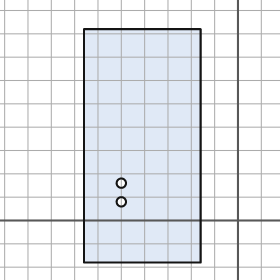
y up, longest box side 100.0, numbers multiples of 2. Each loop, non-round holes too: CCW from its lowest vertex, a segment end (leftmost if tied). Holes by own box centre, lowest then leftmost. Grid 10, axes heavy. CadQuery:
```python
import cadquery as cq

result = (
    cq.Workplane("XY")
    .moveTo(-66.0, -18.0)
    .lineTo(-16.0, -18.0)
    .lineTo(-16.0, 82.0)
    .lineTo(-66.0, 82.0)
    .close()
    .moveTo(-50.0, 8.0)
    .circle(2.0)
    .moveTo(-50.0, 16.0)
    .circle(2.0)
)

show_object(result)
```